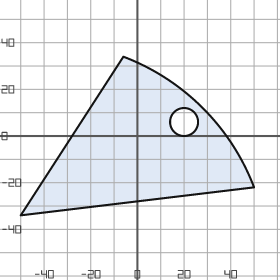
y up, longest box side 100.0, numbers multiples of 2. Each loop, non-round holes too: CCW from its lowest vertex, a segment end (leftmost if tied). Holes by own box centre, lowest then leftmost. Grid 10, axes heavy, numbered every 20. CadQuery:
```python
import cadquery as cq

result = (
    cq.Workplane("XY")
    .moveTo(-50.0, -34.0)
    .lineTo(50.0, -22.0)
    .threePointArc((28.0, 12.0), (-6.0, 34.0))
    .close()
    .moveTo(20.0, 6.0)
    .circle(6.0)
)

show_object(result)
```